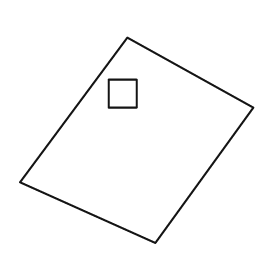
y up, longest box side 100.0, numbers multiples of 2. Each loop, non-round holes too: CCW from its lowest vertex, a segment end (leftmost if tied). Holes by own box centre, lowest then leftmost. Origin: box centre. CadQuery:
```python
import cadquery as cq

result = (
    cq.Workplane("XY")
    .moveTo(8.0, -44.0)
    .lineTo(50.0, 14.0)
    .lineTo(-4.0, 44.0)
    .lineTo(-50.0, -18.0)
    .close()
    .moveTo(-12.0, 14.0)
    .lineTo(0.0, 14.0)
    .lineTo(0.0, 26.0)
    .lineTo(-12.0, 26.0)
    .close()
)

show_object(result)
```